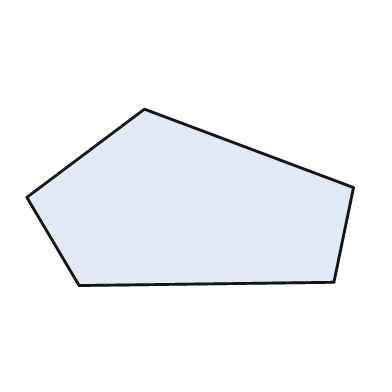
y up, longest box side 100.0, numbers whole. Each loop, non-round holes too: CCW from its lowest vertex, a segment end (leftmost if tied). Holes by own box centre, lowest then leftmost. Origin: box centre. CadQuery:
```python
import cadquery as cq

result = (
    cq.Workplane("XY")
    .moveTo(-34.0, -27.0)
    .lineTo(44.0, -26.0)
    .lineTo(50.0, 3.0)
    .lineTo(-14.0, 27.0)
    .lineTo(-50.0, 0.0)
    .close()
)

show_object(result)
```